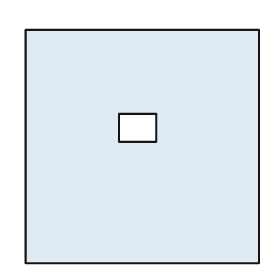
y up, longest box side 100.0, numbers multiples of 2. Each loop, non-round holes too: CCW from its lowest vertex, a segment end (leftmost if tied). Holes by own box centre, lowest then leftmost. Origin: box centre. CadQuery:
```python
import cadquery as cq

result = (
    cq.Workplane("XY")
    .moveTo(-50.0, -50.0)
    .lineTo(50.0, -50.0)
    .lineTo(50.0, 50.0)
    .lineTo(-50.0, 50.0)
    .close()
    .moveTo(-10.0, 2.0)
    .lineTo(6.0, 2.0)
    .lineTo(6.0, 14.0)
    .lineTo(-10.0, 14.0)
    .close()
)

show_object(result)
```